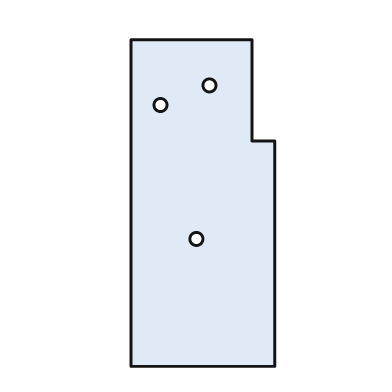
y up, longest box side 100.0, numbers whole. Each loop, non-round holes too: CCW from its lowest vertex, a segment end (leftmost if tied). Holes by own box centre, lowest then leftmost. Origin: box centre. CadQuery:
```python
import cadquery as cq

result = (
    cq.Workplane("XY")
    .moveTo(-22.0, -50.0)
    .lineTo(22.0, -50.0)
    .lineTo(22.0, 19.0)
    .lineTo(15.0, 19.0)
    .lineTo(15.0, 50.0)
    .lineTo(-22.0, 50.0)
    .close()
    .moveTo(-2.0, -11.0)
    .circle(2.0)
    .moveTo(-13.0, 30.0)
    .circle(2.0)
    .moveTo(2.0, 36.0)
    .circle(2.0)
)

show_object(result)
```